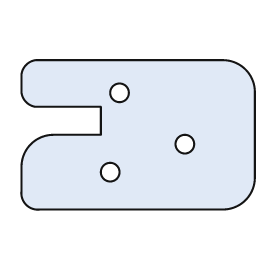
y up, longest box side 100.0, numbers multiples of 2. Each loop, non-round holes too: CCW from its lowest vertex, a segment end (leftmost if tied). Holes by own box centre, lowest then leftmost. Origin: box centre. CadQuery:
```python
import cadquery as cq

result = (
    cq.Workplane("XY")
    .moveTo(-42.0, -32.0)
    .lineTo(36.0, -32.0)
    .threePointArc((46.0, -28.0), (50.0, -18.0))
    .lineTo(50.0, 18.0)
    .threePointArc((46.0, 28.0), (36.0, 32.0))
    .lineTo(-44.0, 32.0)
    .threePointArc((-48.0, 30.0), (-50.0, 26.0))
    .lineTo(-50.0, 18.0)
    .threePointArc((-48.0, 14.0), (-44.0, 12.0))
    .lineTo(-16.0, 12.0)
    .lineTo(-16.0, 0.0)
    .lineTo(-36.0, 0.0)
    .threePointArc((-46.0, -4.0), (-50.0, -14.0))
    .lineTo(-50.0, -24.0)
    .threePointArc((-48.0, -30.0), (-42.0, -32.0))
    .close()
    .moveTo(-12.0, -16.0)
    .circle(4.0)
    .moveTo(20.0, -4.0)
    .circle(4.0)
    .moveTo(-8.0, 18.0)
    .circle(4.0)
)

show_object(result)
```